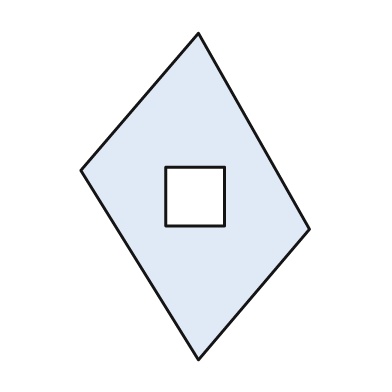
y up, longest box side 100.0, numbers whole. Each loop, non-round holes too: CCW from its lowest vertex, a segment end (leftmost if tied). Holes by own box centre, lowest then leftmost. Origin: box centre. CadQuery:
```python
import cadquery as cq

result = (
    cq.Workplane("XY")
    .moveTo(1.0, -50.0)
    .lineTo(35.0, -10.0)
    .lineTo(1.0, 50.0)
    .lineTo(-35.0, 8.0)
    .close()
    .moveTo(-9.0, -9.0)
    .lineTo(9.0, -9.0)
    .lineTo(9.0, 9.0)
    .lineTo(-9.0, 9.0)
    .close()
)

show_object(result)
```